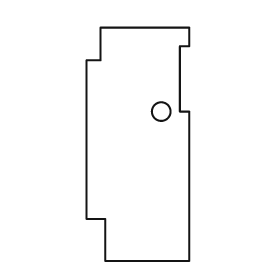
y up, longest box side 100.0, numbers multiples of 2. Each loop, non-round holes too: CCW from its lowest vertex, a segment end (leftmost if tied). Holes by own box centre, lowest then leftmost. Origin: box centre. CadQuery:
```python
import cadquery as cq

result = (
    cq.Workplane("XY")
    .moveTo(-14.0, -50.0)
    .lineTo(22.0, -50.0)
    .lineTo(22.0, 14.0)
    .lineTo(18.0, 14.0)
    .lineTo(18.0, 42.0)
    .lineTo(22.0, 42.0)
    .lineTo(22.0, 50.0)
    .lineTo(-16.0, 50.0)
    .lineTo(-16.0, 36.0)
    .lineTo(-22.0, 36.0)
    .lineTo(-22.0, -32.0)
    .lineTo(-14.0, -32.0)
    .close()
    .moveTo(10.0, 14.0)
    .circle(4.0)
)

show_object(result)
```